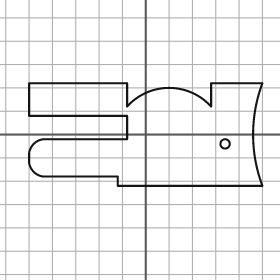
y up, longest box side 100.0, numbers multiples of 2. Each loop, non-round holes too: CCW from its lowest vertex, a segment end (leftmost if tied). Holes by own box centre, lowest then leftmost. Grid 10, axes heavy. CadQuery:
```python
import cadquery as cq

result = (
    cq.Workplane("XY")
    .moveTo(-12.0, -22.0)
    .lineTo(50.0, -22.0)
    .threePointArc((46.0, 0.0), (50.0, 22.0))
    .lineTo(28.0, 22.0)
    .lineTo(28.0, 12.0)
    .threePointArc((10.0, 20.0), (-8.0, 12.0))
    .lineTo(-8.0, 22.0)
    .lineTo(-50.0, 22.0)
    .lineTo(-50.0, 8.0)
    .lineTo(-8.0, 8.0)
    .lineTo(-8.0, -2.0)
    .lineTo(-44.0, -2.0)
    .threePointArc((-48.0, -4.0), (-50.0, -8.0))
    .lineTo(-50.0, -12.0)
    .threePointArc((-48.0, -16.0), (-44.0, -18.0))
    .lineTo(-12.0, -18.0)
    .close()
    .moveTo(34.0, -4.0)
    .circle(2.0)
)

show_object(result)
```